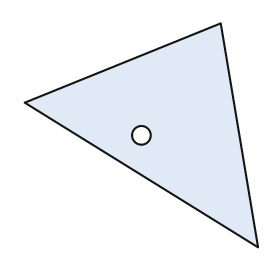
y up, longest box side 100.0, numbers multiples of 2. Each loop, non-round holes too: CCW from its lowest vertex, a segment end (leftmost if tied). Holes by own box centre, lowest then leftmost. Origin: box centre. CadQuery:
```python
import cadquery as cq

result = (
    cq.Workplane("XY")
    .moveTo(50.0, -48.0)
    .lineTo(34.0, 48.0)
    .lineTo(-50.0, 14.0)
    .close()
    .moveTo(0.0, 0.0)
    .circle(4.0)
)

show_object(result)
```